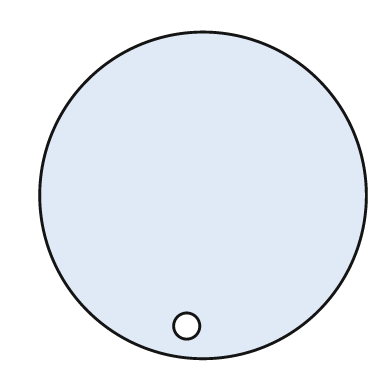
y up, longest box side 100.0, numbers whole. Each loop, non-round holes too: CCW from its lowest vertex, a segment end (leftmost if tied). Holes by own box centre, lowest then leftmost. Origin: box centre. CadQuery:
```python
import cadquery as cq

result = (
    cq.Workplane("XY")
    .moveTo(0.0, 0.0)
    .circle(50.0)
    .moveTo(-5.0, -40.0)
    .circle(4.0)
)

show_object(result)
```